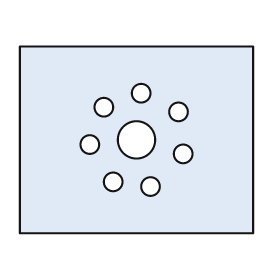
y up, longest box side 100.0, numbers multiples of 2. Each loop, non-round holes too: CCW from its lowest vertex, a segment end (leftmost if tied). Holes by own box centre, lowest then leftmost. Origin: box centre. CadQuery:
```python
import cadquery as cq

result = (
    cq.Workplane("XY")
    .moveTo(-50.0, -40.0)
    .lineTo(50.0, -40.0)
    .lineTo(50.0, 40.0)
    .lineTo(-50.0, 40.0)
    .close()
    .moveTo(6.0, -20.0)
    .circle(4.0)
    .moveTo(-10.0, -18.0)
    .circle(4.0)
    .moveTo(20.0, -6.0)
    .circle(4.0)
    .moveTo(-20.0, -2.0)
    .circle(4.0)
    .moveTo(0.0, 0.0)
    .circle(8.0)
    .moveTo(18.0, 12.0)
    .circle(4.0)
    .moveTo(-14.0, 14.0)
    .circle(4.0)
    .moveTo(2.0, 20.0)
    .circle(4.0)
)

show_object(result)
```